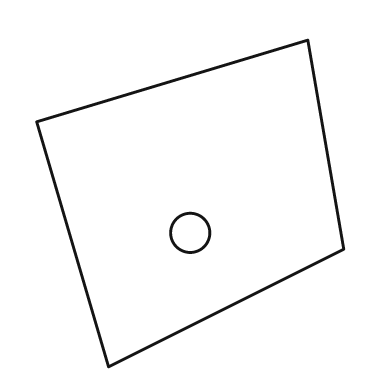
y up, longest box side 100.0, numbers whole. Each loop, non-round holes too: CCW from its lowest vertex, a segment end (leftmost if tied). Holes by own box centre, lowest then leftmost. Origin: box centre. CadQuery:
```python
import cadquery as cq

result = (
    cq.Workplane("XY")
    .moveTo(-25.0, -50.0)
    .lineTo(47.0, -14.0)
    .lineTo(36.0, 50.0)
    .lineTo(-47.0, 25.0)
    .close()
    .moveTo(0.0, -9.0)
    .circle(6.0)
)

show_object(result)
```